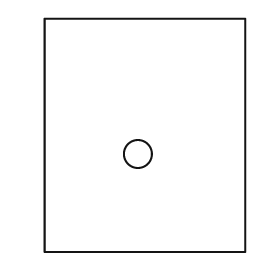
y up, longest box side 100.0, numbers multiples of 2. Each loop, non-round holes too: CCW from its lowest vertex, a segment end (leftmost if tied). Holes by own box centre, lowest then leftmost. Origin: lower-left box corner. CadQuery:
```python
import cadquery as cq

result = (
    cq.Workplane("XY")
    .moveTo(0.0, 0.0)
    .lineTo(86.0, 0.0)
    .lineTo(86.0, 100.0)
    .lineTo(0.0, 100.0)
    .close()
    .moveTo(40.0, 42.0)
    .circle(6.0)
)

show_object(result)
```